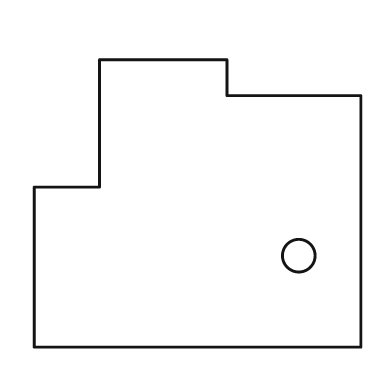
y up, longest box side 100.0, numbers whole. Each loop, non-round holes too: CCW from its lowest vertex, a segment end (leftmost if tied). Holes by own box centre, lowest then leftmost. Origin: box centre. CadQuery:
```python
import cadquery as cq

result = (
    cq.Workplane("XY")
    .moveTo(-50.0, -44.0)
    .lineTo(50.0, -44.0)
    .lineTo(50.0, 33.0)
    .lineTo(9.0, 33.0)
    .lineTo(9.0, 44.0)
    .lineTo(-30.0, 44.0)
    .lineTo(-30.0, 5.0)
    .lineTo(-50.0, 5.0)
    .close()
    .moveTo(31.0, -16.0)
    .circle(5.0)
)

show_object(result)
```